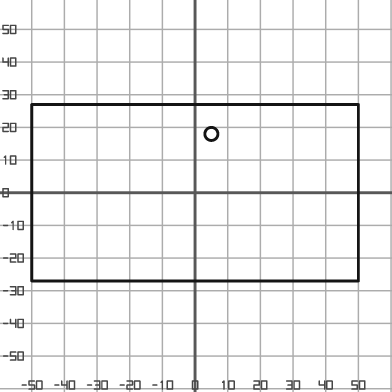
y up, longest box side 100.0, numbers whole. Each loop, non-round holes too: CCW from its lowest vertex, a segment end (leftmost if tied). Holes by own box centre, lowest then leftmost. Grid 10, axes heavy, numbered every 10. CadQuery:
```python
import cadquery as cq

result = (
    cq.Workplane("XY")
    .moveTo(-50.0, -27.0)
    .lineTo(50.0, -27.0)
    .lineTo(50.0, 27.0)
    .lineTo(-50.0, 27.0)
    .close()
    .moveTo(5.0, 18.0)
    .circle(2.0)
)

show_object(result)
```